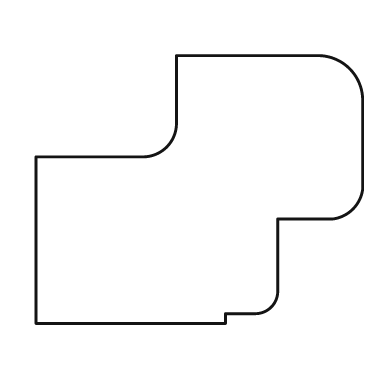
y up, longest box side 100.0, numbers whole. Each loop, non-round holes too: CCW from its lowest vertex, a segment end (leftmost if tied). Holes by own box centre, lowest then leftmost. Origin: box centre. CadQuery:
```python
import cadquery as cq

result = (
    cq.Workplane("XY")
    .moveTo(-50.0, -41.0)
    .lineTo(8.0, -41.0)
    .lineTo(8.0, -38.0)
    .lineTo(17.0, -38.0)
    .threePointArc((22.0, -36.0), (24.0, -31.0))
    .lineTo(24.0, -9.0)
    .lineTo(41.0, -9.0)
    .threePointArc((47.0, -6.0), (50.0, 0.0))
    .lineTo(50.0, 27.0)
    .threePointArc((46.0, 37.0), (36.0, 41.0))
    .lineTo(-7.0, 41.0)
    .lineTo(-7.0, 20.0)
    .threePointArc((-10.0, 13.0), (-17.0, 10.0))
    .lineTo(-50.0, 10.0)
    .close()
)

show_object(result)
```